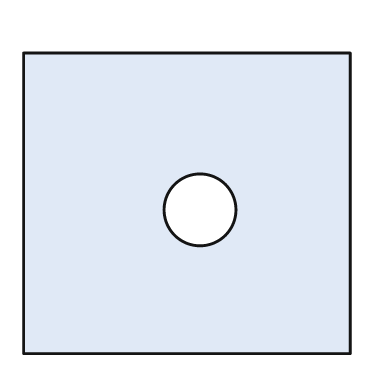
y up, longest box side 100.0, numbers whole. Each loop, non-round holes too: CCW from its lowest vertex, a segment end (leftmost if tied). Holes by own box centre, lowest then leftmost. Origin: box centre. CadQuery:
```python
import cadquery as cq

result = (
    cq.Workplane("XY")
    .moveTo(-50.0, -46.0)
    .lineTo(50.0, -46.0)
    .lineTo(50.0, 46.0)
    .lineTo(-50.0, 46.0)
    .close()
    .moveTo(4.0, -2.0)
    .circle(11.0)
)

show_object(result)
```